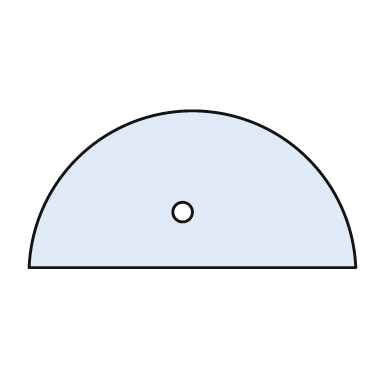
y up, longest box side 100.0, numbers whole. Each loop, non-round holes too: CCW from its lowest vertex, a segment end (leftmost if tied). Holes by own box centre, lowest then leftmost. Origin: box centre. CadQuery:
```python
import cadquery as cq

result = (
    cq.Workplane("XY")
    .moveTo(-50.0, -24.0)
    .lineTo(50.0, -24.0)
    .threePointArc((0.0, 24.0), (-50.0, -24.0))
    .close()
    .moveTo(-3.0, -7.0)
    .circle(3.0)
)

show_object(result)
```